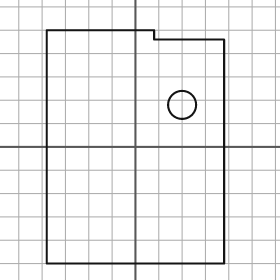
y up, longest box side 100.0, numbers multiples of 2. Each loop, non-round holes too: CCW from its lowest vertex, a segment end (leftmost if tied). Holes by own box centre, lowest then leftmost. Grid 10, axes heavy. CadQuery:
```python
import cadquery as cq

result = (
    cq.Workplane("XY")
    .moveTo(-38.0, -50.0)
    .lineTo(38.0, -50.0)
    .lineTo(38.0, 46.0)
    .lineTo(8.0, 46.0)
    .lineTo(8.0, 50.0)
    .lineTo(-38.0, 50.0)
    .close()
    .moveTo(20.0, 18.0)
    .circle(6.0)
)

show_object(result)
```